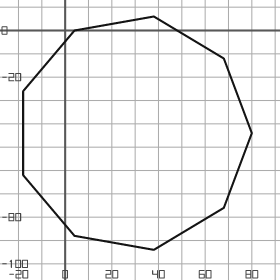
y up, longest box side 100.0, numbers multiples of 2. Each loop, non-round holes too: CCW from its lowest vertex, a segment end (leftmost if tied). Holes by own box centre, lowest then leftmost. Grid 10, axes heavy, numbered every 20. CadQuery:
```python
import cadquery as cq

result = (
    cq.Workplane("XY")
    .moveTo(38.0, -94.0)
    .lineTo(68.0, -76.0)
    .lineTo(80.0, -44.0)
    .lineTo(68.0, -12.0)
    .lineTo(38.0, 6.0)
    .lineTo(4.0, 0.0)
    .lineTo(-18.0, -26.0)
    .lineTo(-18.0, -62.0)
    .lineTo(4.0, -88.0)
    .close()
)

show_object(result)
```